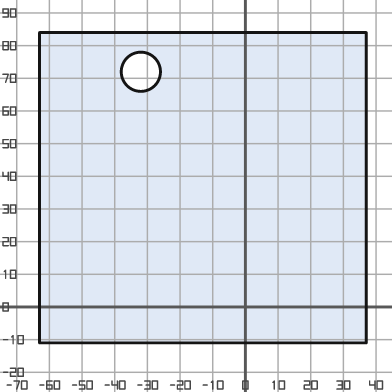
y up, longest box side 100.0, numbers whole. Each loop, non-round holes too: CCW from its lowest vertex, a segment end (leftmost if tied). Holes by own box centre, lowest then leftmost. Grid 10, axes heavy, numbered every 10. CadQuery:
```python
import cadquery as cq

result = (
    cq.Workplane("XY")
    .moveTo(-63.0, -11.0)
    .lineTo(37.0, -11.0)
    .lineTo(37.0, 84.0)
    .lineTo(-63.0, 84.0)
    .close()
    .moveTo(-32.0, 72.0)
    .circle(6.0)
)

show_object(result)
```